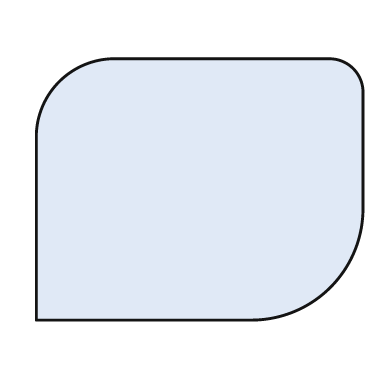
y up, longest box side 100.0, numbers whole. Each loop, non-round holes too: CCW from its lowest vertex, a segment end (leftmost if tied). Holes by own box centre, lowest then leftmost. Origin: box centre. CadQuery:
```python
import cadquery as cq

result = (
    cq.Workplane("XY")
    .moveTo(-50.0, -40.0)
    .lineTo(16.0, -40.0)
    .threePointArc((40.0, -30.0), (50.0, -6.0))
    .lineTo(50.0, 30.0)
    .threePointArc((47.0, 37.0), (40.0, 40.0))
    .lineTo(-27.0, 40.0)
    .threePointArc((-43.0, 33.0), (-50.0, 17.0))
    .close()
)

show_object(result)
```